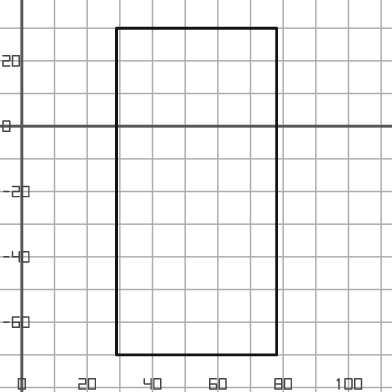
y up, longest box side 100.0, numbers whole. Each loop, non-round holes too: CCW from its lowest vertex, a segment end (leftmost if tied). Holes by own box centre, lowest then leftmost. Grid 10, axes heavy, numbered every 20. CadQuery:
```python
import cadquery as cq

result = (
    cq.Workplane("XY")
    .moveTo(29.0, -70.0)
    .lineTo(78.0, -70.0)
    .lineTo(78.0, 30.0)
    .lineTo(29.0, 30.0)
    .close()
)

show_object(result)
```